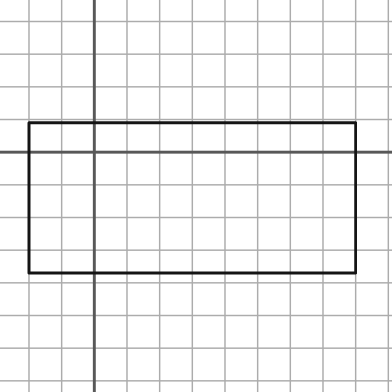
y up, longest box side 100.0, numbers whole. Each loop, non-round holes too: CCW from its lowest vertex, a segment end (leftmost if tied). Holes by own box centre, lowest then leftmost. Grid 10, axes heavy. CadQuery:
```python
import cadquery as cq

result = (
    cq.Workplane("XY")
    .moveTo(-20.0, -37.0)
    .lineTo(80.0, -37.0)
    .lineTo(80.0, 9.0)
    .lineTo(-20.0, 9.0)
    .close()
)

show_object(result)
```